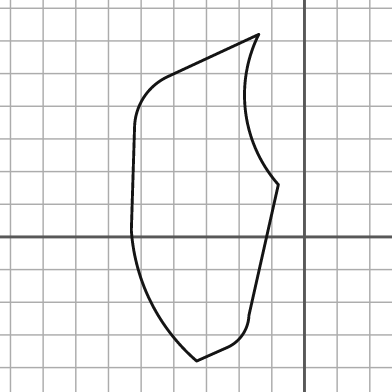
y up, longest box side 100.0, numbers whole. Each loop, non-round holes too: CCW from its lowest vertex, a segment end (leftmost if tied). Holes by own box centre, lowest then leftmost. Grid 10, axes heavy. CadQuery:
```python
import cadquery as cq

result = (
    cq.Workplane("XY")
    .moveTo(-33.0, -38.0)
    .lineTo(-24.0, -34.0)
    .threePointArc((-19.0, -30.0), (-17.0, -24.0))
    .lineTo(-8.0, 16.0)
    .threePointArc((-18.0, 38.0), (-14.0, 62.0))
    .lineTo(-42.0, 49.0)
    .threePointArc((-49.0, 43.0), (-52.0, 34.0))
    .lineTo(-53.0, 2.0)
    .threePointArc((-47.0, -20.0), (-33.0, -38.0))
    .close()
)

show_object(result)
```